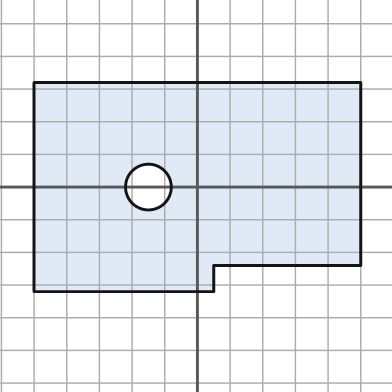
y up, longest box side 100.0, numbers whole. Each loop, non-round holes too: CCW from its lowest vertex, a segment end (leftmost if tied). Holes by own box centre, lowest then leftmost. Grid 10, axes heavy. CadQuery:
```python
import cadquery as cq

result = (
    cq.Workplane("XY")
    .moveTo(-50.0, -32.0)
    .lineTo(5.0, -32.0)
    .lineTo(5.0, -24.0)
    .lineTo(50.0, -24.0)
    .lineTo(50.0, 32.0)
    .lineTo(-50.0, 32.0)
    .close()
    .moveTo(-15.0, 0.0)
    .circle(7.0)
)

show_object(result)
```